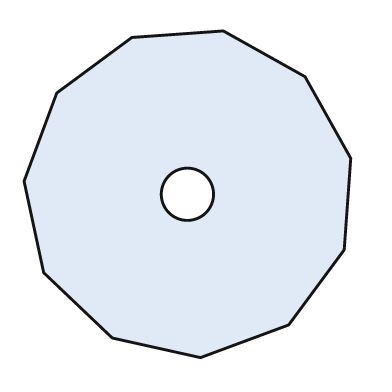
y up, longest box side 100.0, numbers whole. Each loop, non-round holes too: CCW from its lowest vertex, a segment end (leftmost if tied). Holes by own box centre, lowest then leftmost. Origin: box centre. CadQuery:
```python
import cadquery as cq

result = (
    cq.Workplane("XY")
    .moveTo(4.0, -50.0)
    .lineTo(31.0, -40.0)
    .lineTo(48.0, -17.0)
    .lineTo(50.0, 11.0)
    .lineTo(36.0, 36.0)
    .lineTo(11.0, 50.0)
    .lineTo(-17.0, 48.0)
    .lineTo(-40.0, 31.0)
    .lineTo(-50.0, 4.0)
    .lineTo(-44.0, -24.0)
    .lineTo(-23.0, -44.0)
    .close()
    .moveTo(0.0, 0.0)
    .circle(8.0)
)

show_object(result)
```